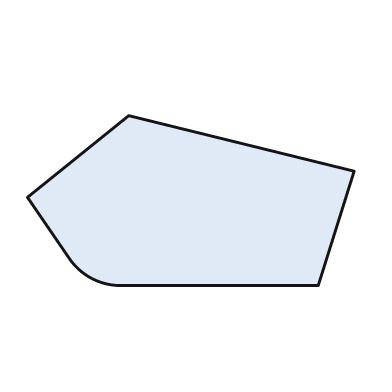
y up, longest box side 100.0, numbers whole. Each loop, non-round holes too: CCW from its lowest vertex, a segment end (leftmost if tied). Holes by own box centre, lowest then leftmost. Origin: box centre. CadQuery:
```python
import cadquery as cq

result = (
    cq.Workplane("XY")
    .moveTo(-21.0, -26.0)
    .lineTo(39.0, -26.0)
    .lineTo(50.0, 9.0)
    .lineTo(-19.0, 26.0)
    .lineTo(-50.0, 1.0)
    .lineTo(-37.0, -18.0)
    .threePointArc((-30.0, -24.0), (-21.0, -26.0))
    .close()
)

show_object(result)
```